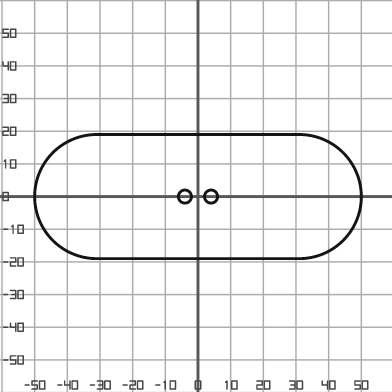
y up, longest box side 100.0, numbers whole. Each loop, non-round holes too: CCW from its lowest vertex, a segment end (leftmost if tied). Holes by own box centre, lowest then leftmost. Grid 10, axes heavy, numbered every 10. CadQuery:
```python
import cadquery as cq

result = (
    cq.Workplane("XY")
    .moveTo(-31.0, -19.0)
    .lineTo(31.0, -19.0)
    .threePointArc((50.0, 0.0), (31.0, 19.0))
    .lineTo(-31.0, 19.0)
    .threePointArc((-50.0, 0.0), (-31.0, -19.0))
    .close()
    .moveTo(-4.0, 0.0)
    .circle(2.0)
    .moveTo(4.0, 0.0)
    .circle(2.0)
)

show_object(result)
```